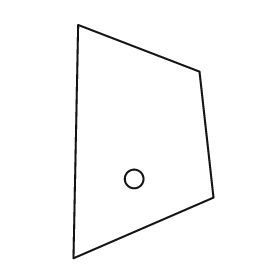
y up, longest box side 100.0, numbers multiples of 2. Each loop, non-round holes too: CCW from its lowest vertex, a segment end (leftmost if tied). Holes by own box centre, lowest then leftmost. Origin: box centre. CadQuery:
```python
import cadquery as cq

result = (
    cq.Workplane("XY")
    .moveTo(-30.0, -50.0)
    .lineTo(30.0, -24.0)
    .lineTo(24.0, 30.0)
    .lineTo(-28.0, 50.0)
    .close()
    .moveTo(-4.0, -16.0)
    .circle(4.0)
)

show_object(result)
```